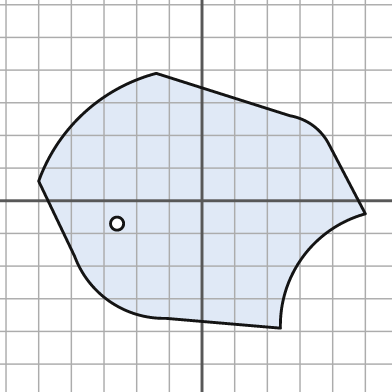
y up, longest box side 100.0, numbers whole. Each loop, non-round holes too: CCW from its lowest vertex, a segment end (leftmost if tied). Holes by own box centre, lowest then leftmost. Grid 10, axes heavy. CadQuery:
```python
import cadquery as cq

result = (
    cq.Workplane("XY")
    .moveTo(24.0, -39.0)
    .threePointArc((31.0, -17.0), (50.0, -4.0))
    .lineTo(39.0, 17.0)
    .threePointArc((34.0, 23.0), (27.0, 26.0))
    .lineTo(-14.0, 39.0)
    .threePointArc((-36.0, 27.0), (-50.0, 6.0))
    .lineTo(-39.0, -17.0)
    .threePointArc((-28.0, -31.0), (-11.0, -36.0))
    .close()
    .moveTo(-26.0, -7.0)
    .circle(2.0)
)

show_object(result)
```